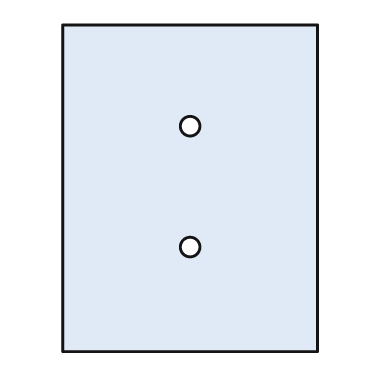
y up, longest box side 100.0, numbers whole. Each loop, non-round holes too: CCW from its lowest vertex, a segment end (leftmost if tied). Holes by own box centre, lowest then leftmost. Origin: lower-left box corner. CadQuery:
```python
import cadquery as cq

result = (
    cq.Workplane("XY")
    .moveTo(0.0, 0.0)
    .lineTo(78.0, 0.0)
    .lineTo(78.0, 100.0)
    .lineTo(0.0, 100.0)
    .close()
    .moveTo(39.0, 32.0)
    .circle(3.0)
    .moveTo(39.0, 69.0)
    .circle(3.0)
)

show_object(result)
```